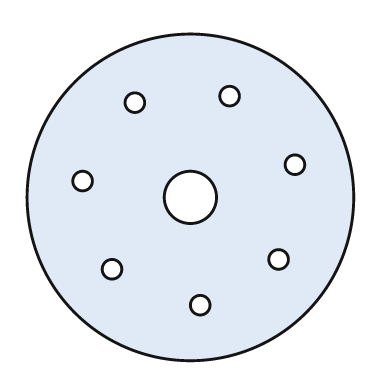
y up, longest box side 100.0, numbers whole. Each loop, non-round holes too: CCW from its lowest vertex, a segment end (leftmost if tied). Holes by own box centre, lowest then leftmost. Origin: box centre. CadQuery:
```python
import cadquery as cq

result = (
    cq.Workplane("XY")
    .moveTo(0.0, 0.0)
    .circle(50.0)
    .moveTo(3.0, -33.0)
    .circle(3.0)
    .moveTo(-24.0, -22.0)
    .circle(3.0)
    .moveTo(27.0, -19.0)
    .circle(3.0)
    .moveTo(0.0, 0.0)
    .circle(8.0)
    .moveTo(-33.0, 5.0)
    .circle(3.0)
    .moveTo(32.0, 10.0)
    .circle(3.0)
    .moveTo(-17.0, 29.0)
    .circle(3.0)
    .moveTo(12.0, 31.0)
    .circle(3.0)
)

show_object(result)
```